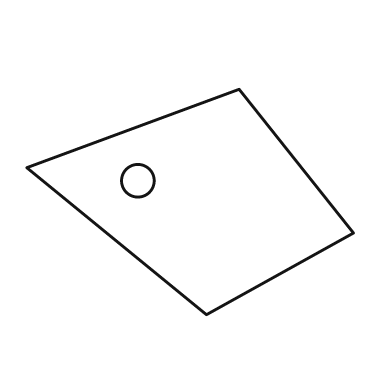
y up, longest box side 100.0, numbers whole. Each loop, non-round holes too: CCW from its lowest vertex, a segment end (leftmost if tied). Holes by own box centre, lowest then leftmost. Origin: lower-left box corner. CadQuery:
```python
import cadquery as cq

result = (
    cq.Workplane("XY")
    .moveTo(55.0, 0.0)
    .lineTo(100.0, 25.0)
    .lineTo(65.0, 69.0)
    .lineTo(0.0, 45.0)
    .close()
    .moveTo(34.0, 41.0)
    .circle(5.0)
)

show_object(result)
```